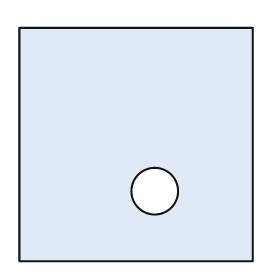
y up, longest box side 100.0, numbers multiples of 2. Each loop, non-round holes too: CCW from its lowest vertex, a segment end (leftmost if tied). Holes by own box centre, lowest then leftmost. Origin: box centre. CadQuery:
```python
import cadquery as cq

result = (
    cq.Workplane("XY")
    .moveTo(-50.0, -50.0)
    .lineTo(50.0, -50.0)
    .lineTo(50.0, 50.0)
    .lineTo(-50.0, 50.0)
    .close()
    .moveTo(8.0, -20.0)
    .circle(10.0)
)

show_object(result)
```